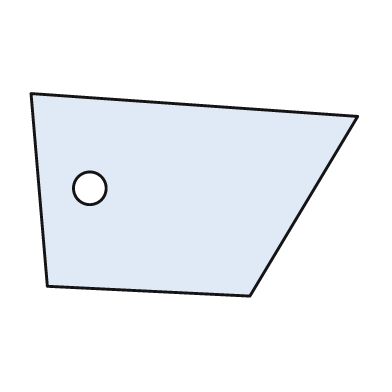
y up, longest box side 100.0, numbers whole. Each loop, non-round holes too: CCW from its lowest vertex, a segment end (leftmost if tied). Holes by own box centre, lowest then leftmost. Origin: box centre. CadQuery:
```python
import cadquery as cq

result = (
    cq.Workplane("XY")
    .moveTo(17.0, -31.0)
    .lineTo(50.0, 24.0)
    .lineTo(-50.0, 31.0)
    .lineTo(-45.0, -28.0)
    .close()
    .moveTo(-32.0, 2.0)
    .circle(5.0)
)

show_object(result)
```